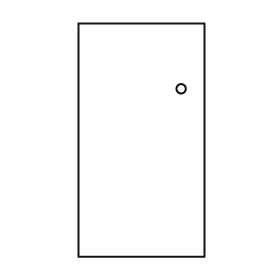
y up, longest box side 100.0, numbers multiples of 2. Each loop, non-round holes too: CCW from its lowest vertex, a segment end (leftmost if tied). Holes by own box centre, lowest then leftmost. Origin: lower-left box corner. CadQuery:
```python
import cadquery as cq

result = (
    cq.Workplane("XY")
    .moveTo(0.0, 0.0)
    .lineTo(54.0, 0.0)
    .lineTo(54.0, 100.0)
    .lineTo(0.0, 100.0)
    .close()
    .moveTo(44.0, 72.0)
    .circle(2.0)
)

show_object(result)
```